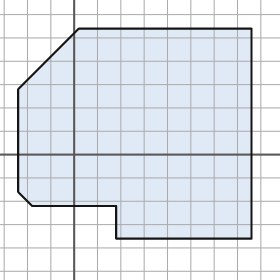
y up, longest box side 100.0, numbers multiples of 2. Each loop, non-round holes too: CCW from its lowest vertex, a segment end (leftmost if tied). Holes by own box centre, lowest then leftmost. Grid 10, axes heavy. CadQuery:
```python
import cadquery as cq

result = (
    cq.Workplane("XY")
    .moveTo(18.0, -36.0)
    .lineTo(76.0, -36.0)
    .lineTo(76.0, 54.0)
    .lineTo(2.0, 54.0)
    .lineTo(-24.0, 28.0)
    .lineTo(-24.0, -16.0)
    .lineTo(-18.0, -22.0)
    .lineTo(18.0, -22.0)
    .close()
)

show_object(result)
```